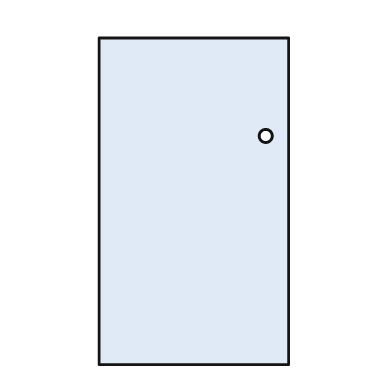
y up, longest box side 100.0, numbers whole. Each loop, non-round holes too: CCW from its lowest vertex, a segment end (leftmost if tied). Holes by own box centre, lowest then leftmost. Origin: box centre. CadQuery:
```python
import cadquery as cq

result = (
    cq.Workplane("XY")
    .moveTo(-29.0, -50.0)
    .lineTo(29.0, -50.0)
    .lineTo(29.0, 50.0)
    .lineTo(-29.0, 50.0)
    .close()
    .moveTo(22.0, 20.0)
    .circle(2.0)
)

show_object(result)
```